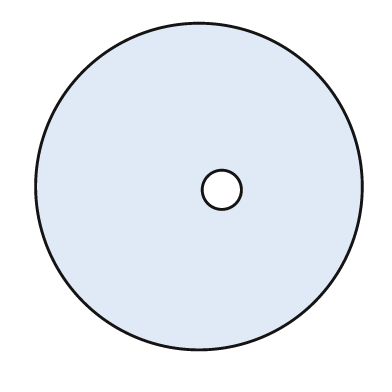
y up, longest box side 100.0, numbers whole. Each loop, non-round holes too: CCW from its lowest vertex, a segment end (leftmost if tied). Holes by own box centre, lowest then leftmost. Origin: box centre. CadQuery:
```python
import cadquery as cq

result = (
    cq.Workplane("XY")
    .moveTo(0.0, 0.0)
    .circle(50.0)
    .moveTo(7.0, -1.0)
    .circle(6.0)
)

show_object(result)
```